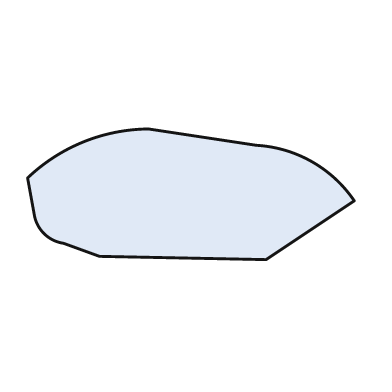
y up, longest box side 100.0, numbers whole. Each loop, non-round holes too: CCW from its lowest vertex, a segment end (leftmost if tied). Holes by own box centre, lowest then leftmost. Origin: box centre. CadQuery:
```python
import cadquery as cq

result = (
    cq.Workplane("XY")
    .moveTo(23.0, -20.0)
    .lineTo(50.0, -2.0)
    .threePointArc((37.0, 10.0), (20.0, 15.0))
    .lineTo(-13.0, 20.0)
    .threePointArc((-33.0, 16.0), (-50.0, 5.0))
    .lineTo(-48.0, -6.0)
    .threePointArc((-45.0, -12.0), (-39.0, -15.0))
    .lineTo(-28.0, -19.0)
    .close()
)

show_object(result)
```